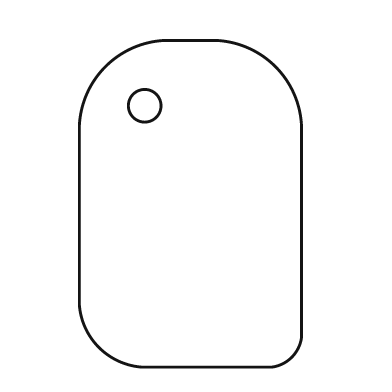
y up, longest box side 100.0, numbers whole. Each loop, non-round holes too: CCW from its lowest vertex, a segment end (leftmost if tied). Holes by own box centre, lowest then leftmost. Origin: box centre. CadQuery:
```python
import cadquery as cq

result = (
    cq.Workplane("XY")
    .moveTo(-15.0, -50.0)
    .lineTo(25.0, -50.0)
    .threePointArc((31.0, -47.0), (34.0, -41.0))
    .lineTo(34.0, 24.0)
    .threePointArc((26.0, 42.0), (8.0, 50.0))
    .lineTo(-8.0, 50.0)
    .threePointArc((-26.0, 42.0), (-34.0, 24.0))
    .lineTo(-34.0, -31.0)
    .threePointArc((-28.0, -44.0), (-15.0, -50.0))
    .close()
    .moveTo(-14.0, 30.0)
    .circle(5.0)
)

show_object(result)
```